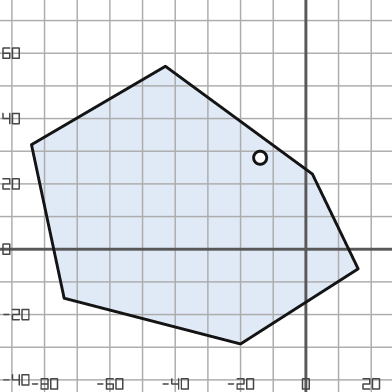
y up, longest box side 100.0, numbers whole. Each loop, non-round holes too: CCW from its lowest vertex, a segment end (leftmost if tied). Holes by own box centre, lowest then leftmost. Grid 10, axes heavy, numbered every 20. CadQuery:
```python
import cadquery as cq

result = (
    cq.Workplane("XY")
    .moveTo(-20.0, -29.0)
    .lineTo(16.0, -6.0)
    .lineTo(2.0, 23.0)
    .lineTo(-43.0, 56.0)
    .lineTo(-84.0, 32.0)
    .lineTo(-74.0, -15.0)
    .close()
    .moveTo(-14.0, 28.0)
    .circle(2.0)
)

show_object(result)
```